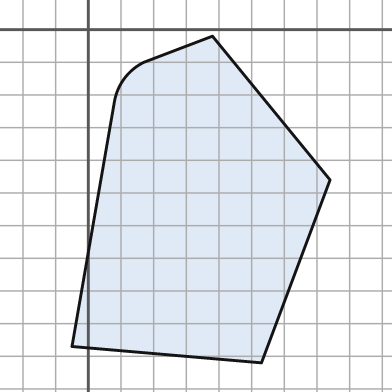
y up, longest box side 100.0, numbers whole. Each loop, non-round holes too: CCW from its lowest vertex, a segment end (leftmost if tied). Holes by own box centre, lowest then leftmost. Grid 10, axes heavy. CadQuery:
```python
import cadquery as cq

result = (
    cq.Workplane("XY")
    .moveTo(53.0, -102.0)
    .lineTo(74.0, -46.0)
    .lineTo(38.0, -2.0)
    .lineTo(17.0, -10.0)
    .threePointArc((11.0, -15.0), (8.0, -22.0))
    .lineTo(-5.0, -97.0)
    .close()
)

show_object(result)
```